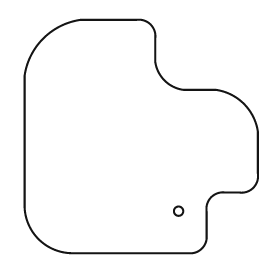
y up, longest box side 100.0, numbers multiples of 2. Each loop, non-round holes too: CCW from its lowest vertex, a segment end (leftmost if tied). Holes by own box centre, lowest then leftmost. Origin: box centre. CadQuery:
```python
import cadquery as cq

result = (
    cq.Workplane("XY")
    .moveTo(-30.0, -50.0)
    .lineTo(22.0, -50.0)
    .threePointArc((26.0, -48.0), (28.0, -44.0))
    .lineTo(28.0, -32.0)
    .threePointArc((30.0, -26.0), (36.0, -24.0))
    .lineTo(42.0, -24.0)
    .threePointArc((48.0, -22.0), (50.0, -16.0))
    .lineTo(50.0, 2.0)
    .threePointArc((44.0, 14.0), (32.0, 20.0))
    .lineTo(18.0, 20.0)
    .threePointArc((10.0, 24.0), (6.0, 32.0))
    .lineTo(6.0, 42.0)
    .threePointArc((4.0, 48.0), (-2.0, 50.0))
    .lineTo(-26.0, 50.0)
    .threePointArc((-42.0, 42.0), (-50.0, 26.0))
    .lineTo(-50.0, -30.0)
    .threePointArc((-44.0, -44.0), (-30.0, -50.0))
    .close()
    .moveTo(16.0, -32.0)
    .circle(2.0)
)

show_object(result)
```